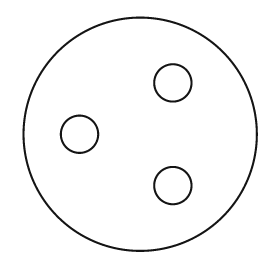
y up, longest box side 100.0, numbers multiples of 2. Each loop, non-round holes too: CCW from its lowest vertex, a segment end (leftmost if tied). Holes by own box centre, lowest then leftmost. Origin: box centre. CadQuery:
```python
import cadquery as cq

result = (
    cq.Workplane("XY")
    .moveTo(0.0, 0.0)
    .circle(50.0)
    .moveTo(14.0, -22.0)
    .circle(8.0)
    .moveTo(-26.0, 0.0)
    .circle(8.0)
    .moveTo(14.0, 22.0)
    .circle(8.0)
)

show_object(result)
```